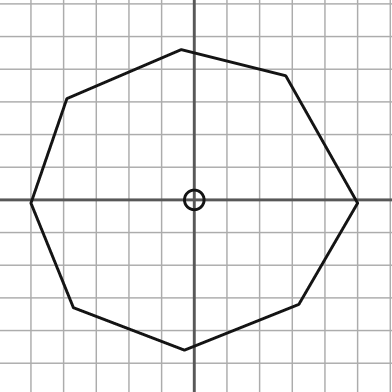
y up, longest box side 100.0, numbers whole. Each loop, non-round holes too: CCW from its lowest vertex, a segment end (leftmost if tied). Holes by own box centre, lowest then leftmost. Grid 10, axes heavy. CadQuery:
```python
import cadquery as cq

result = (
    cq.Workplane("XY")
    .moveTo(-3.0, -46.0)
    .lineTo(32.0, -32.0)
    .lineTo(50.0, -1.0)
    .lineTo(28.0, 38.0)
    .lineTo(-4.0, 46.0)
    .lineTo(-39.0, 31.0)
    .lineTo(-50.0, -1.0)
    .lineTo(-37.0, -33.0)
    .close()
    .moveTo(0.0, 0.0)
    .circle(3.0)
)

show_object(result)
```